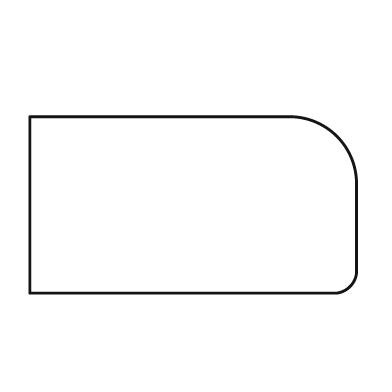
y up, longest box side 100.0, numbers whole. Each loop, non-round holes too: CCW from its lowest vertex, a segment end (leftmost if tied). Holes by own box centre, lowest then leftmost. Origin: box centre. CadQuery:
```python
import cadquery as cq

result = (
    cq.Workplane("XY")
    .moveTo(-50.0, -27.0)
    .lineTo(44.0, -27.0)
    .threePointArc((48.0, -25.0), (50.0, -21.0))
    .lineTo(50.0, 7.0)
    .threePointArc((44.0, 21.0), (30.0, 27.0))
    .lineTo(-50.0, 27.0)
    .close()
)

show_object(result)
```